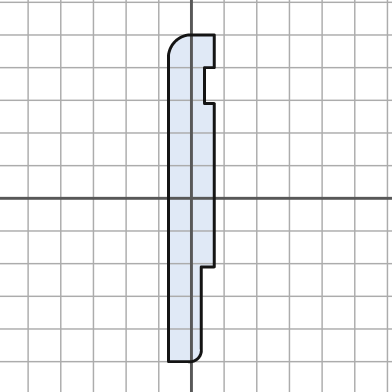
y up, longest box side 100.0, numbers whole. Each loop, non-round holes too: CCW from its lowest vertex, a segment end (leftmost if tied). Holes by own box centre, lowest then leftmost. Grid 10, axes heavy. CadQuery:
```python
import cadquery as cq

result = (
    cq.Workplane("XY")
    .moveTo(-7.0, -50.0)
    .lineTo(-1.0, -50.0)
    .threePointArc((2.0, -49.0), (3.0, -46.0))
    .lineTo(3.0, -21.0)
    .lineTo(7.0, -21.0)
    .lineTo(7.0, 29.0)
    .lineTo(4.0, 29.0)
    .lineTo(4.0, 40.0)
    .lineTo(7.0, 40.0)
    .lineTo(7.0, 50.0)
    .lineTo(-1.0, 50.0)
    .threePointArc((-5.0, 48.0), (-7.0, 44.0))
    .close()
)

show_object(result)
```